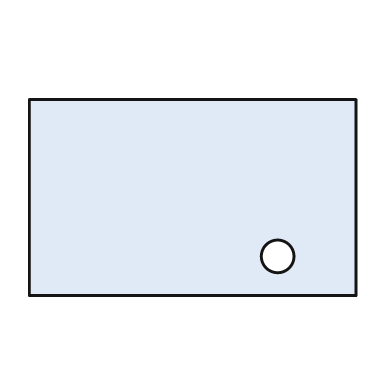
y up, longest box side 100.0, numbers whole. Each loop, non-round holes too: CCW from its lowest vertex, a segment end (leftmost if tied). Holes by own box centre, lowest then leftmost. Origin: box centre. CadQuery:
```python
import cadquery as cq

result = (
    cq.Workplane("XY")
    .moveTo(-50.0, -30.0)
    .lineTo(50.0, -30.0)
    .lineTo(50.0, 30.0)
    .lineTo(-50.0, 30.0)
    .close()
    .moveTo(26.0, -18.0)
    .circle(5.0)
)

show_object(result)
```